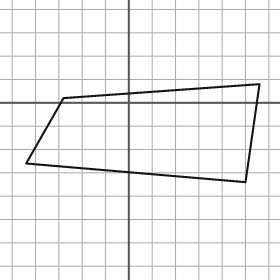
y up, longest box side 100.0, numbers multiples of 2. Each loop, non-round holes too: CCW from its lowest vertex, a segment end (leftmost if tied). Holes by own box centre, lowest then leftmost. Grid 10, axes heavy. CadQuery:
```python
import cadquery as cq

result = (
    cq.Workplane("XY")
    .moveTo(50.0, -34.0)
    .lineTo(56.0, 8.0)
    .lineTo(-28.0, 2.0)
    .lineTo(-44.0, -26.0)
    .close()
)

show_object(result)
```